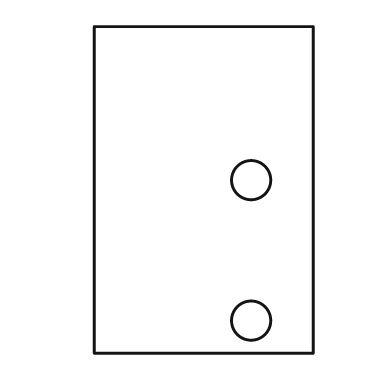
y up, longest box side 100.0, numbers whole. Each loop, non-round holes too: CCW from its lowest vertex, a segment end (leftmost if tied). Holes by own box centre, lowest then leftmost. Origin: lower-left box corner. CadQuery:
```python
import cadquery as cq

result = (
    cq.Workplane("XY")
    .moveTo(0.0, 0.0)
    .lineTo(67.0, 0.0)
    .lineTo(67.0, 100.0)
    .lineTo(0.0, 100.0)
    .close()
    .moveTo(48.0, 10.0)
    .circle(6.0)
    .moveTo(48.0, 53.0)
    .circle(6.0)
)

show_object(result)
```